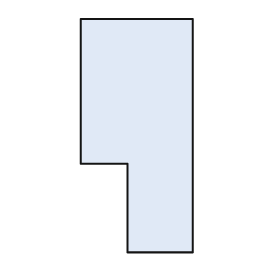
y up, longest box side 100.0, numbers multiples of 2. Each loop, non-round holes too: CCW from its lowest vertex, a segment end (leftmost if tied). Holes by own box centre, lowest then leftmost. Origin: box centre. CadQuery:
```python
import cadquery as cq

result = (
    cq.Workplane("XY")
    .moveTo(-4.0, -50.0)
    .lineTo(24.0, -50.0)
    .lineTo(24.0, 50.0)
    .lineTo(-24.0, 50.0)
    .lineTo(-24.0, -12.0)
    .lineTo(-4.0, -12.0)
    .close()
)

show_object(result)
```